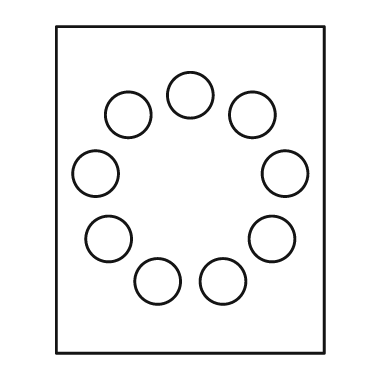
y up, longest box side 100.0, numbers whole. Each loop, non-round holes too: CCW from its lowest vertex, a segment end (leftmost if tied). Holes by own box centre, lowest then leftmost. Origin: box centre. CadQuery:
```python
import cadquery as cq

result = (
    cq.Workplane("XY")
    .moveTo(-41.0, -50.0)
    .lineTo(41.0, -50.0)
    .lineTo(41.0, 50.0)
    .lineTo(-41.0, 50.0)
    .close()
    .moveTo(-10.0, -28.0)
    .circle(7.0)
    .moveTo(10.0, -28.0)
    .circle(7.0)
    .moveTo(-25.0, -15.0)
    .circle(7.0)
    .moveTo(25.0, -15.0)
    .circle(7.0)
    .moveTo(-29.0, 5.0)
    .circle(7.0)
    .moveTo(29.0, 5.0)
    .circle(7.0)
    .moveTo(-19.0, 23.0)
    .circle(7.0)
    .moveTo(19.0, 23.0)
    .circle(7.0)
    .moveTo(0.0, 29.0)
    .circle(7.0)
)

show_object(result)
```